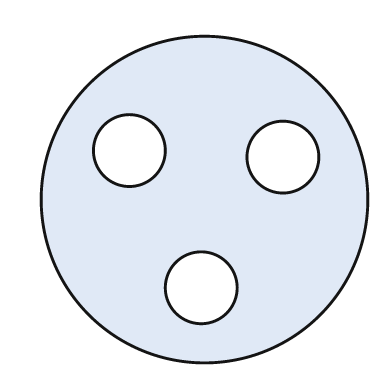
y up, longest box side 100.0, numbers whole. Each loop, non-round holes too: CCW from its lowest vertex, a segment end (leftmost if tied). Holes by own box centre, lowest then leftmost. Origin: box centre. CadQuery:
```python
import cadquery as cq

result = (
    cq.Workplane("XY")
    .moveTo(0.0, 0.0)
    .circle(50.0)
    .moveTo(-1.0, -27.0)
    .circle(11.0)
    .moveTo(24.0, 13.0)
    .circle(11.0)
    .moveTo(-23.0, 15.0)
    .circle(11.0)
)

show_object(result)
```